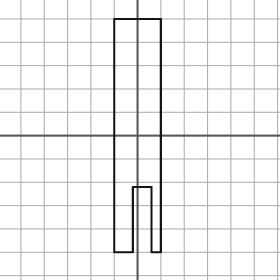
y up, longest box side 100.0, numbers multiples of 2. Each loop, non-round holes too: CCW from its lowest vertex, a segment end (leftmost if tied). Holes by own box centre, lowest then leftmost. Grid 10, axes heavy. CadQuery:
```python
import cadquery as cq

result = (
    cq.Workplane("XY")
    .moveTo(-10.0, -50.0)
    .lineTo(-2.0, -50.0)
    .lineTo(-2.0, -22.0)
    .lineTo(6.0, -22.0)
    .lineTo(6.0, -50.0)
    .lineTo(10.0, -50.0)
    .lineTo(10.0, 50.0)
    .lineTo(-10.0, 50.0)
    .close()
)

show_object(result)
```